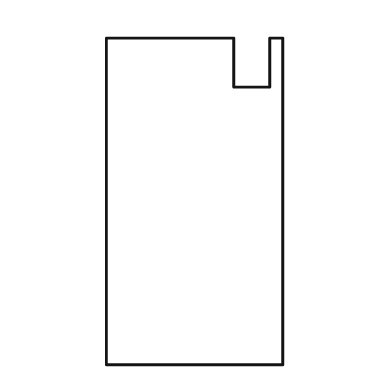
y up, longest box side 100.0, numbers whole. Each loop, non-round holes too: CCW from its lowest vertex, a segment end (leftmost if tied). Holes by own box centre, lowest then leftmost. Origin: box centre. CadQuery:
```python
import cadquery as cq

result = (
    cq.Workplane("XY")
    .moveTo(-27.0, -50.0)
    .lineTo(27.0, -50.0)
    .lineTo(27.0, 50.0)
    .lineTo(23.0, 50.0)
    .lineTo(23.0, 35.0)
    .lineTo(12.0, 35.0)
    .lineTo(12.0, 50.0)
    .lineTo(-27.0, 50.0)
    .close()
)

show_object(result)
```